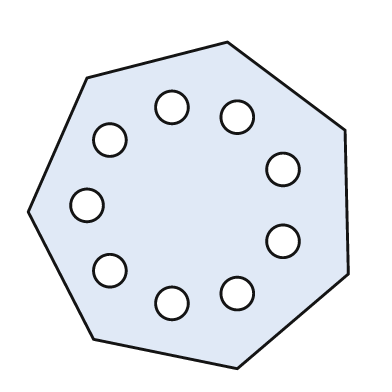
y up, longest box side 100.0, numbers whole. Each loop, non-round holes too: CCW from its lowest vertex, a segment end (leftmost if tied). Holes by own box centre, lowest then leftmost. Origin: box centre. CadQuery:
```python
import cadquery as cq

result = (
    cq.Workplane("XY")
    .moveTo(15.0, -50.0)
    .lineTo(49.0, -21.0)
    .lineTo(48.0, 23.0)
    .lineTo(12.0, 50.0)
    .lineTo(-31.0, 39.0)
    .lineTo(-49.0, -2.0)
    .lineTo(-29.0, -41.0)
    .close()
    .moveTo(-5.0, -30.0)
    .circle(5.0)
    .moveTo(15.0, -27.0)
    .circle(5.0)
    .moveTo(-24.0, -20.0)
    .circle(5.0)
    .moveTo(29.0, -11.0)
    .circle(5.0)
    .moveTo(-31.0, 0.0)
    .circle(5.0)
    .moveTo(29.0, 11.0)
    .circle(5.0)
    .moveTo(-24.0, 20.0)
    .circle(5.0)
    .moveTo(15.0, 27.0)
    .circle(5.0)
    .moveTo(-5.0, 30.0)
    .circle(5.0)
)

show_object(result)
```